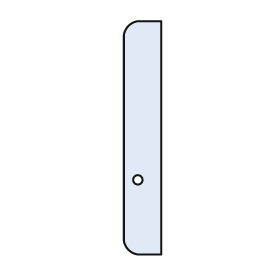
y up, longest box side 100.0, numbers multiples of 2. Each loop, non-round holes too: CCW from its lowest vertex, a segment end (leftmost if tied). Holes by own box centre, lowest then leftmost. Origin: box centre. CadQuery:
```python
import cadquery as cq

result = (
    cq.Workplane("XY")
    .moveTo(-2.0, -50.0)
    .lineTo(8.0, -50.0)
    .lineTo(8.0, 50.0)
    .lineTo(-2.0, 50.0)
    .threePointArc((-6.0, 48.0), (-8.0, 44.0))
    .lineTo(-8.0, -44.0)
    .threePointArc((-6.0, -48.0), (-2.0, -50.0))
    .close()
    .moveTo(-2.0, -18.0)
    .circle(2.0)
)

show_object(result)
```